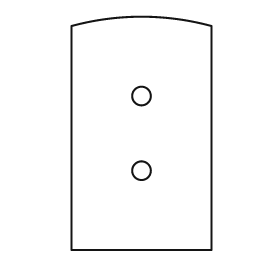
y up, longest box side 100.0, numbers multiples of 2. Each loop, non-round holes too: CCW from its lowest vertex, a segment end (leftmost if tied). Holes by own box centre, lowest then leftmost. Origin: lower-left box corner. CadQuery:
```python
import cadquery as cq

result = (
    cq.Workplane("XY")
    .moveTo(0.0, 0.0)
    .lineTo(60.0, 0.0)
    .lineTo(60.0, 96.0)
    .threePointArc((30.0, 100.0), (0.0, 96.0))
    .close()
    .moveTo(30.0, 34.0)
    .circle(4.0)
    .moveTo(30.0, 66.0)
    .circle(4.0)
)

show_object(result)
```